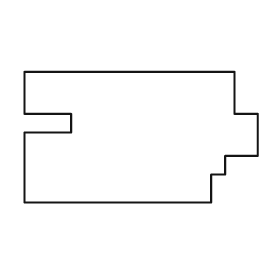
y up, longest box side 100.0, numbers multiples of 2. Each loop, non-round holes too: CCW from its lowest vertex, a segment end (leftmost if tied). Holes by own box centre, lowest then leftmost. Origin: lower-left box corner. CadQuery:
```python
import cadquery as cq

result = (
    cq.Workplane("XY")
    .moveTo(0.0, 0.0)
    .lineTo(80.0, 0.0)
    .lineTo(80.0, 12.0)
    .lineTo(86.0, 12.0)
    .lineTo(86.0, 20.0)
    .lineTo(100.0, 20.0)
    .lineTo(100.0, 38.0)
    .lineTo(90.0, 38.0)
    .lineTo(90.0, 56.0)
    .lineTo(0.0, 56.0)
    .lineTo(0.0, 38.0)
    .lineTo(20.0, 38.0)
    .lineTo(20.0, 30.0)
    .lineTo(0.0, 30.0)
    .close()
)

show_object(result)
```